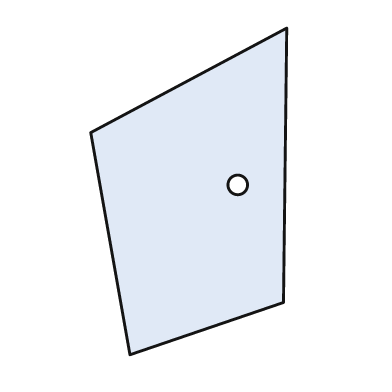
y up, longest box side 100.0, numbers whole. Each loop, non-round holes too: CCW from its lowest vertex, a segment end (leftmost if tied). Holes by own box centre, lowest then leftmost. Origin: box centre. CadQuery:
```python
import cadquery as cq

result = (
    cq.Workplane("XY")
    .moveTo(-18.0, -50.0)
    .lineTo(29.0, -34.0)
    .lineTo(30.0, 50.0)
    .lineTo(-30.0, 18.0)
    .close()
    .moveTo(15.0, 2.0)
    .circle(3.0)
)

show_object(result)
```